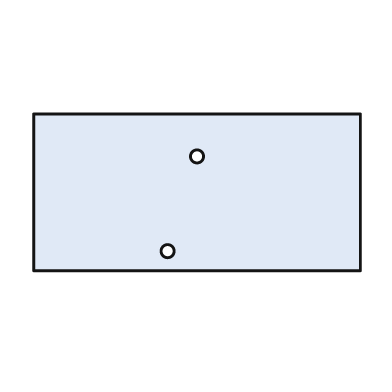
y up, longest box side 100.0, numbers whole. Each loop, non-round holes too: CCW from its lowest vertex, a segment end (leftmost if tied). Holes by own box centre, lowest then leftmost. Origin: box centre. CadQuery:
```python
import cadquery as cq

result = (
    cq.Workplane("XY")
    .moveTo(-50.0, -24.0)
    .lineTo(50.0, -24.0)
    .lineTo(50.0, 24.0)
    .lineTo(-50.0, 24.0)
    .close()
    .moveTo(-9.0, -18.0)
    .circle(2.0)
    .moveTo(0.0, 11.0)
    .circle(2.0)
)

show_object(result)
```